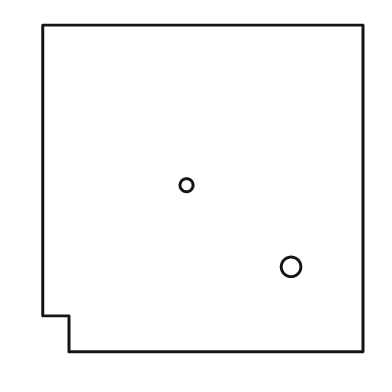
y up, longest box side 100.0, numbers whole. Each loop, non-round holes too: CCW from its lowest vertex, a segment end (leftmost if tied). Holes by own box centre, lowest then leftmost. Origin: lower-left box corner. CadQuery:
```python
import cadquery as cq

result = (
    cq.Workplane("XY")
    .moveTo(8.0, 0.0)
    .lineTo(98.0, 0.0)
    .lineTo(98.0, 100.0)
    .lineTo(0.0, 100.0)
    .lineTo(0.0, 11.0)
    .lineTo(8.0, 11.0)
    .close()
    .moveTo(76.0, 26.0)
    .circle(3.0)
    .moveTo(44.0, 51.0)
    .circle(2.0)
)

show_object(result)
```